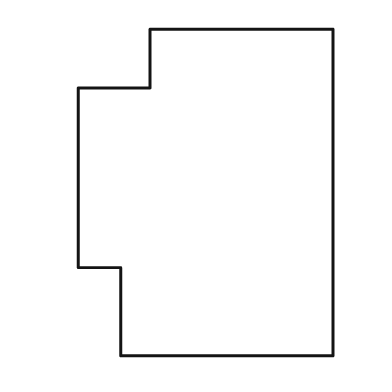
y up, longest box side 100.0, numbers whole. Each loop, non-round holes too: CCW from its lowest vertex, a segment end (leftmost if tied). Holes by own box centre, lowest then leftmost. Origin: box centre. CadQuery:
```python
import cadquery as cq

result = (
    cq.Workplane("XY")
    .moveTo(-26.0, -50.0)
    .lineTo(39.0, -50.0)
    .lineTo(39.0, 50.0)
    .lineTo(-17.0, 50.0)
    .lineTo(-17.0, 32.0)
    .lineTo(-39.0, 32.0)
    .lineTo(-39.0, -23.0)
    .lineTo(-26.0, -23.0)
    .close()
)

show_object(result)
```